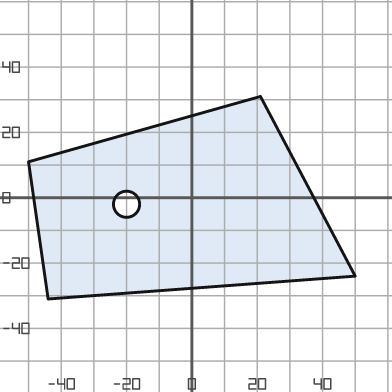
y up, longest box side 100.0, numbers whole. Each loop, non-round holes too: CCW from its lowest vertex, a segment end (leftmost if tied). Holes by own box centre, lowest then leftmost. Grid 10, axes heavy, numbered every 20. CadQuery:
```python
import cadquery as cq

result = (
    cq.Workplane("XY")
    .moveTo(-44.0, -31.0)
    .lineTo(50.0, -24.0)
    .lineTo(21.0, 31.0)
    .lineTo(-50.0, 11.0)
    .close()
    .moveTo(-20.0, -2.0)
    .circle(4.0)
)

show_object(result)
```